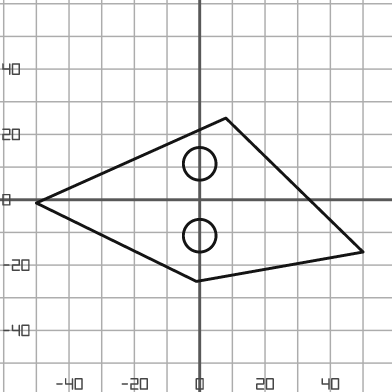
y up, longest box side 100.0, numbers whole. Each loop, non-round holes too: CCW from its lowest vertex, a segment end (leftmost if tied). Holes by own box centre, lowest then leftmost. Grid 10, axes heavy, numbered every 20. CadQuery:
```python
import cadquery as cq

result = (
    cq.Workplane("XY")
    .moveTo(-1.0, -25.0)
    .lineTo(50.0, -16.0)
    .lineTo(8.0, 25.0)
    .lineTo(-50.0, -1.0)
    .close()
    .moveTo(0.0, -11.0)
    .circle(5.0)
    .moveTo(0.0, 11.0)
    .circle(5.0)
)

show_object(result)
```